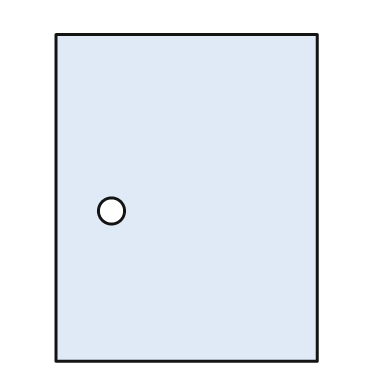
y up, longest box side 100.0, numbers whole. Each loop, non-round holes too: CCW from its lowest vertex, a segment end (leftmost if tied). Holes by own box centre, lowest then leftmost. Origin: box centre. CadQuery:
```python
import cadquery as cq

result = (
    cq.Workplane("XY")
    .moveTo(-40.0, -50.0)
    .lineTo(40.0, -50.0)
    .lineTo(40.0, 50.0)
    .lineTo(-40.0, 50.0)
    .close()
    .moveTo(-23.0, -4.0)
    .circle(4.0)
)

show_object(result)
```